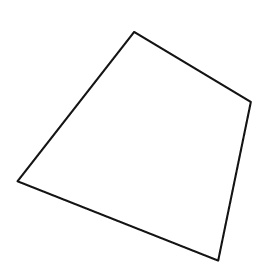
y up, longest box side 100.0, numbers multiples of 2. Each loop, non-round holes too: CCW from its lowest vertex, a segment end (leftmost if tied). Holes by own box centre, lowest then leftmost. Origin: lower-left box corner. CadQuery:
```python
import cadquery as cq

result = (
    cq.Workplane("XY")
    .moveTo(86.0, 0.0)
    .lineTo(100.0, 68.0)
    .lineTo(50.0, 98.0)
    .lineTo(0.0, 34.0)
    .close()
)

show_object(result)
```